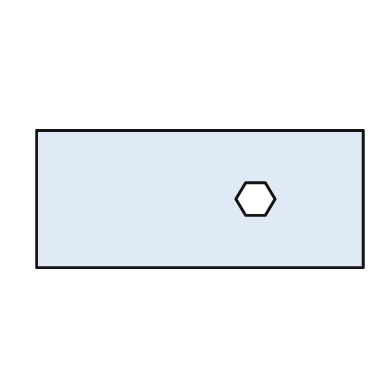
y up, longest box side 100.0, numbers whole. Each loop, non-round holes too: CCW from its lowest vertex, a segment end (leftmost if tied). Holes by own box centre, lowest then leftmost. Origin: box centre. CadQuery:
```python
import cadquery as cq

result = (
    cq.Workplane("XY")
    .moveTo(-50.0, -21.0)
    .lineTo(50.0, -21.0)
    .lineTo(50.0, 21.0)
    .lineTo(-50.0, 21.0)
    .close()
    .moveTo(14.0, -5.0)
    .lineTo(20.0, -5.0)
    .lineTo(23.0, 0.0)
    .lineTo(20.0, 5.0)
    .lineTo(14.0, 5.0)
    .lineTo(11.0, 0.0)
    .close()
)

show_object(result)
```